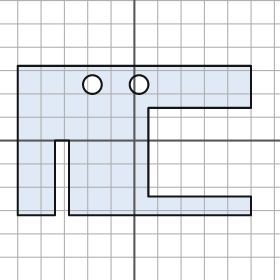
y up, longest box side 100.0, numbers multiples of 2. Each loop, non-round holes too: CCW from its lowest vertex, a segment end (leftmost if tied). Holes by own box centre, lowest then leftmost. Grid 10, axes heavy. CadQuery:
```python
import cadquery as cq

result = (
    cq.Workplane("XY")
    .moveTo(-50.0, -32.0)
    .lineTo(-34.0, -32.0)
    .lineTo(-34.0, 0.0)
    .lineTo(-28.0, 0.0)
    .lineTo(-28.0, -32.0)
    .lineTo(50.0, -32.0)
    .lineTo(50.0, -24.0)
    .lineTo(6.0, -24.0)
    .lineTo(6.0, 14.0)
    .lineTo(50.0, 14.0)
    .lineTo(50.0, 32.0)
    .lineTo(-50.0, 32.0)
    .close()
    .moveTo(-18.0, 24.0)
    .circle(4.0)
    .moveTo(2.0, 24.0)
    .circle(4.0)
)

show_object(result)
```